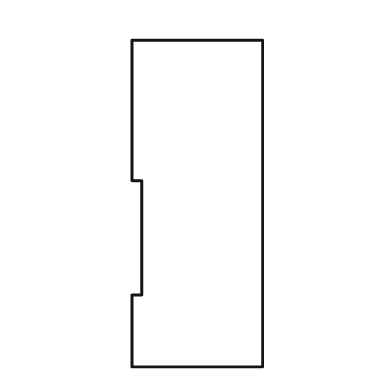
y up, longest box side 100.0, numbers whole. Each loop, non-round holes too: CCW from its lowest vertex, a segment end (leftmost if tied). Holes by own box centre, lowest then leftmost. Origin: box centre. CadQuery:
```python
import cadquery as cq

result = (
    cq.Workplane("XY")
    .moveTo(-20.0, -50.0)
    .lineTo(20.0, -50.0)
    .lineTo(20.0, 50.0)
    .lineTo(-20.0, 50.0)
    .lineTo(-20.0, 7.0)
    .lineTo(-17.0, 7.0)
    .lineTo(-17.0, -28.0)
    .lineTo(-20.0, -28.0)
    .close()
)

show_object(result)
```